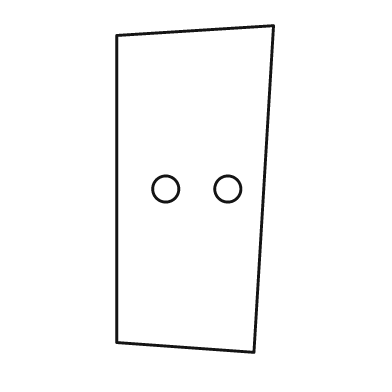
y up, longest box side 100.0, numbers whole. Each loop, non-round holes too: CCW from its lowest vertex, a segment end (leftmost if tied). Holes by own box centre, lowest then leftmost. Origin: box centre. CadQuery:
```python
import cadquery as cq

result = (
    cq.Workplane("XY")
    .moveTo(18.0, -50.0)
    .lineTo(24.0, 50.0)
    .lineTo(-24.0, 47.0)
    .lineTo(-24.0, -47.0)
    .close()
    .moveTo(-9.0, 0.0)
    .circle(4.0)
    .moveTo(10.0, 0.0)
    .circle(4.0)
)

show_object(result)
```